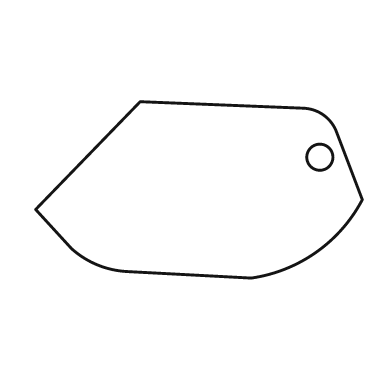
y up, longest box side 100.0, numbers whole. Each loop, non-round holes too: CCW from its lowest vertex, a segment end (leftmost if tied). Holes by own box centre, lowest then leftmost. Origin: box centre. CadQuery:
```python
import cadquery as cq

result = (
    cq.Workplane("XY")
    .moveTo(16.0, -27.0)
    .threePointArc((36.0, -19.0), (50.0, -3.0))
    .lineTo(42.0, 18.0)
    .threePointArc((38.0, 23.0), (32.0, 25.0))
    .lineTo(-18.0, 27.0)
    .lineTo(-50.0, -6.0)
    .lineTo(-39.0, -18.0)
    .threePointArc((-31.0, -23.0), (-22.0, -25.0))
    .close()
    .moveTo(37.0, 10.0)
    .circle(4.0)
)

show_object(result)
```